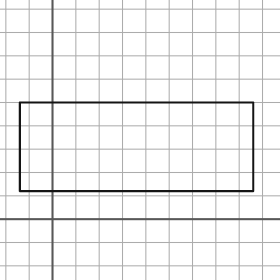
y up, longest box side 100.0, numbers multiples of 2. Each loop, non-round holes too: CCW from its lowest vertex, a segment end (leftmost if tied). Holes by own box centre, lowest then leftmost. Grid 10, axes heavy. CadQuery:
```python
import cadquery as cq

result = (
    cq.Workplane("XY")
    .moveTo(-14.0, 12.0)
    .lineTo(86.0, 12.0)
    .lineTo(86.0, 50.0)
    .lineTo(-14.0, 50.0)
    .close()
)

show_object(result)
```